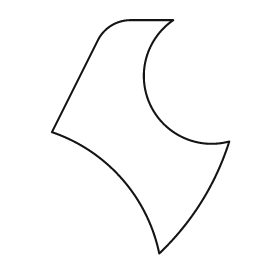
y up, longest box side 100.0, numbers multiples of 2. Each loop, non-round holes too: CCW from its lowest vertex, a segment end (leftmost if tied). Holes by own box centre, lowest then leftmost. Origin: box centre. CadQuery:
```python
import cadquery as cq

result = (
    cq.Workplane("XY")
    .moveTo(8.0, -50.0)
    .threePointArc((26.0, -28.0), (38.0, -2.0))
    .threePointArc((4.0, 14.0), (14.0, 50.0))
    .lineTo(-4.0, 50.0)
    .threePointArc((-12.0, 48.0), (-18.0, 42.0))
    .lineTo(-38.0, 2.0)
    .threePointArc((-8.0, -18.0), (8.0, -50.0))
    .close()
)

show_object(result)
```